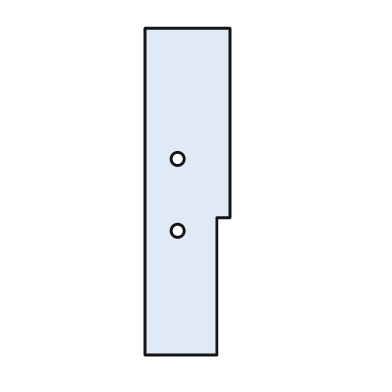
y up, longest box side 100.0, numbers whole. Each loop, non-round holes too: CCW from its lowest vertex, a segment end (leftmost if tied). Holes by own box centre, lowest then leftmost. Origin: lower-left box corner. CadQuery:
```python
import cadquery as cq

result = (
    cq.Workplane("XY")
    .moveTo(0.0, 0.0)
    .lineTo(22.0, 0.0)
    .lineTo(22.0, 42.0)
    .lineTo(26.0, 42.0)
    .lineTo(26.0, 100.0)
    .lineTo(0.0, 100.0)
    .close()
    .moveTo(10.0, 38.0)
    .circle(2.0)
    .moveTo(10.0, 60.0)
    .circle(2.0)
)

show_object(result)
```